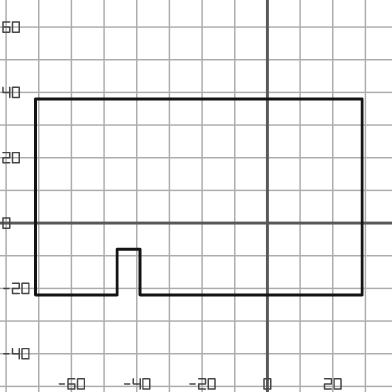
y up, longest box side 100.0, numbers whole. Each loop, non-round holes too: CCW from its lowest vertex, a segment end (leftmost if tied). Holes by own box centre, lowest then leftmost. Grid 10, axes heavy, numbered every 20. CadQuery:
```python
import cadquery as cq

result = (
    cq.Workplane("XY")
    .moveTo(-71.0, -22.0)
    .lineTo(-46.0, -22.0)
    .lineTo(-46.0, -8.0)
    .lineTo(-39.0, -8.0)
    .lineTo(-39.0, -22.0)
    .lineTo(29.0, -22.0)
    .lineTo(29.0, 38.0)
    .lineTo(-71.0, 38.0)
    .close()
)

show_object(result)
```